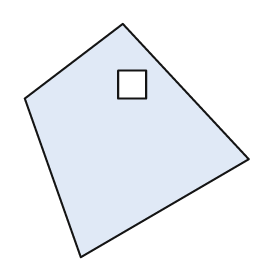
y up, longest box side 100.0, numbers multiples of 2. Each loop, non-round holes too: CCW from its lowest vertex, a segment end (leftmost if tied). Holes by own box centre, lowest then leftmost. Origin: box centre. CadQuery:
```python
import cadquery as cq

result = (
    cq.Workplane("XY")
    .moveTo(-24.0, -50.0)
    .lineTo(48.0, -8.0)
    .lineTo(-6.0, 50.0)
    .lineTo(-48.0, 18.0)
    .close()
    .moveTo(-8.0, 18.0)
    .lineTo(4.0, 18.0)
    .lineTo(4.0, 30.0)
    .lineTo(-8.0, 30.0)
    .close()
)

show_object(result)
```